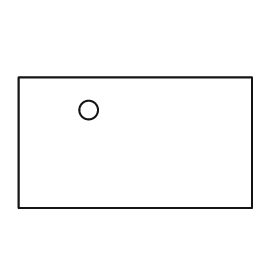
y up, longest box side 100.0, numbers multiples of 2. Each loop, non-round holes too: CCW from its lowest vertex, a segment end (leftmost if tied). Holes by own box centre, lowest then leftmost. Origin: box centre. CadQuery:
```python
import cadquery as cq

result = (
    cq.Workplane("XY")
    .moveTo(-50.0, -28.0)
    .lineTo(50.0, -28.0)
    .lineTo(50.0, 28.0)
    .lineTo(-50.0, 28.0)
    .close()
    .moveTo(-20.0, 14.0)
    .circle(4.0)
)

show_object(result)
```